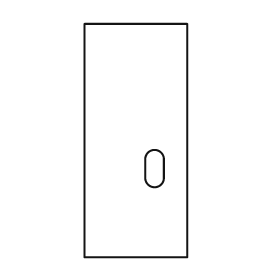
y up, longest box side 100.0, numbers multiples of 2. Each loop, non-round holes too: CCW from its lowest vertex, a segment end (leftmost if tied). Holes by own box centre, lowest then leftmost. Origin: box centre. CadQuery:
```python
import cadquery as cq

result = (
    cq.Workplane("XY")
    .moveTo(-22.0, -50.0)
    .lineTo(22.0, -50.0)
    .lineTo(22.0, 50.0)
    .lineTo(-22.0, 50.0)
    .close()
    .moveTo(4.0, -16.0)
    .threePointArc((8.0, -20.0), (12.0, -16.0))
    .lineTo(12.0, -8.0)
    .threePointArc((8.0, -4.0), (4.0, -8.0))
    .close()
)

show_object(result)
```